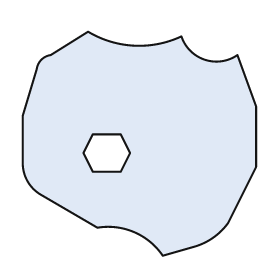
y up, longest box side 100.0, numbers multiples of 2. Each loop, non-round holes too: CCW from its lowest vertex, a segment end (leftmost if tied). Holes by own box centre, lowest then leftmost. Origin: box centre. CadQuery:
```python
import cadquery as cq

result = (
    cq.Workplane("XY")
    .moveTo(10.0, -48.0)
    .lineTo(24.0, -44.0)
    .threePointArc((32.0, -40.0), (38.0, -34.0))
    .lineTo(50.0, -10.0)
    .lineTo(50.0, 16.0)
    .lineTo(42.0, 38.0)
    .threePointArc((28.0, 36.0), (18.0, 46.0))
    .threePointArc((-2.0, 42.0), (-22.0, 48.0))
    .lineTo(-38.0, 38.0)
    .threePointArc((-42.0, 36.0), (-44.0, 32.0))
    .lineTo(-50.0, 12.0)
    .lineTo(-50.0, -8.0)
    .threePointArc((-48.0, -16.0), (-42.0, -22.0))
    .lineTo(-18.0, -36.0)
    .threePointArc((-2.0, -38.0), (10.0, -48.0))
    .close()
    .moveTo(-20.0, -12.0)
    .lineTo(-8.0, -12.0)
    .lineTo(-4.0, -4.0)
    .lineTo(-8.0, 4.0)
    .lineTo(-20.0, 4.0)
    .lineTo(-24.0, -4.0)
    .close()
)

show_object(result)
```